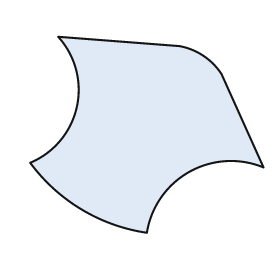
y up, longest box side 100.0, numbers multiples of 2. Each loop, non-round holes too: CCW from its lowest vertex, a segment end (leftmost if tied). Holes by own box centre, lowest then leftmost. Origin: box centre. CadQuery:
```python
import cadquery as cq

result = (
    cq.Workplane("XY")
    .moveTo(0.0, -42.0)
    .threePointArc((18.0, -16.0), (50.0, -14.0))
    .lineTo(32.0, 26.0)
    .threePointArc((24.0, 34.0), (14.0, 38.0))
    .lineTo(-38.0, 42.0)
    .threePointArc((-30.0, 12.0), (-50.0, -12.0))
    .threePointArc((-28.0, -32.0), (0.0, -42.0))
    .close()
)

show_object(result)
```